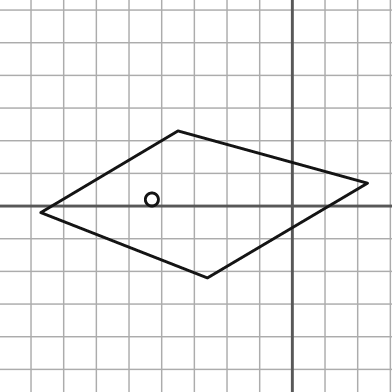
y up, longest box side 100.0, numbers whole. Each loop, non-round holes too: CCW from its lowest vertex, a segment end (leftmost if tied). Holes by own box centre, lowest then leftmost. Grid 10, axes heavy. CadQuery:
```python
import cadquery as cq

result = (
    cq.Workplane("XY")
    .moveTo(-26.0, -22.0)
    .lineTo(23.0, 7.0)
    .lineTo(-35.0, 23.0)
    .lineTo(-77.0, -2.0)
    .close()
    .moveTo(-43.0, 2.0)
    .circle(2.0)
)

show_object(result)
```